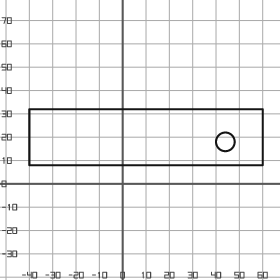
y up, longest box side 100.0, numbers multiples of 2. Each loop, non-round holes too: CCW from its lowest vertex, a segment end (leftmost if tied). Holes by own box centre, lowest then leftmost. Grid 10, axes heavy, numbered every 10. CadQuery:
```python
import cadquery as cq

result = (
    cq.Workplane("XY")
    .moveTo(-40.0, 8.0)
    .lineTo(60.0, 8.0)
    .lineTo(60.0, 32.0)
    .lineTo(-40.0, 32.0)
    .close()
    .moveTo(44.0, 18.0)
    .circle(4.0)
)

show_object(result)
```